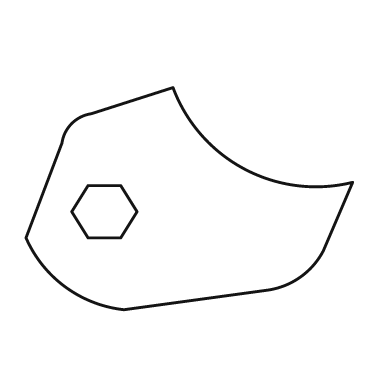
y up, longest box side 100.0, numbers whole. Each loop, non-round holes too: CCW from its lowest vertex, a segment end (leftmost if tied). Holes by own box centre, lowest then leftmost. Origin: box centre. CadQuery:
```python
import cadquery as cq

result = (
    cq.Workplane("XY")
    .moveTo(-20.0, -34.0)
    .lineTo(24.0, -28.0)
    .threePointArc((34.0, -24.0), (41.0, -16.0))
    .lineTo(50.0, 5.0)
    .threePointArc((17.0, 9.0), (-5.0, 34.0))
    .lineTo(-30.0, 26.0)
    .threePointArc((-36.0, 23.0), (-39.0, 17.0))
    .lineTo(-50.0, -12.0)
    .threePointArc((-38.0, -27.0), (-20.0, -34.0))
    .close()
    .moveTo(-31.0, -12.0)
    .lineTo(-21.0, -12.0)
    .lineTo(-16.0, -4.0)
    .lineTo(-21.0, 4.0)
    .lineTo(-31.0, 4.0)
    .lineTo(-36.0, -4.0)
    .close()
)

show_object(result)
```